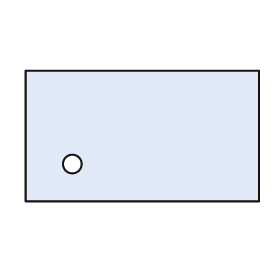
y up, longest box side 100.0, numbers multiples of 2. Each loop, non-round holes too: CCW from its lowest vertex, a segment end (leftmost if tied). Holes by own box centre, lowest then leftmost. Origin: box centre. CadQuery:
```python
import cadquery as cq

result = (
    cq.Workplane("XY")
    .moveTo(-50.0, -28.0)
    .lineTo(50.0, -28.0)
    .lineTo(50.0, 28.0)
    .lineTo(-50.0, 28.0)
    .close()
    .moveTo(-30.0, -12.0)
    .circle(4.0)
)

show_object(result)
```